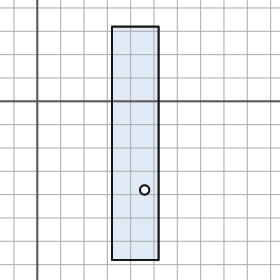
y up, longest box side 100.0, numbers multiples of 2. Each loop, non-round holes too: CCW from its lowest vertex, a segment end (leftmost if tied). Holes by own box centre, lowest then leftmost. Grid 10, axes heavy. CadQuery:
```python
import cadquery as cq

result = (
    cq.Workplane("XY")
    .moveTo(32.0, -68.0)
    .lineTo(52.0, -68.0)
    .lineTo(52.0, 32.0)
    .lineTo(32.0, 32.0)
    .close()
    .moveTo(46.0, -38.0)
    .circle(2.0)
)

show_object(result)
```